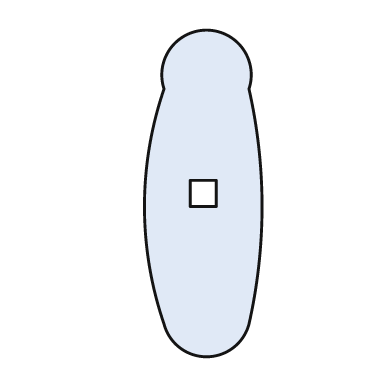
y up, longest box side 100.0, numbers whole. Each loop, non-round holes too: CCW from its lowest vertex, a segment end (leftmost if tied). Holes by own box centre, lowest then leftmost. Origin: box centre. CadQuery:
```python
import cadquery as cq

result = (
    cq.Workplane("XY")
    .moveTo(-12.0, -40.0)
    .threePointArc((1.0, -50.0), (14.0, -40.0))
    .threePointArc((18.0, -4.0), (14.0, 32.0))
    .threePointArc((1.0, 50.0), (-12.0, 32.0))
    .threePointArc((-18.0, -4.0), (-12.0, -40.0))
    .close()
    .moveTo(-4.0, -4.0)
    .lineTo(4.0, -4.0)
    .lineTo(4.0, 4.0)
    .lineTo(-4.0, 4.0)
    .close()
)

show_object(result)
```